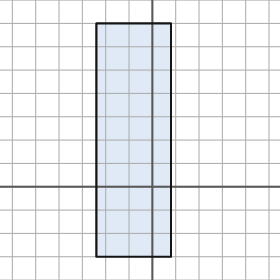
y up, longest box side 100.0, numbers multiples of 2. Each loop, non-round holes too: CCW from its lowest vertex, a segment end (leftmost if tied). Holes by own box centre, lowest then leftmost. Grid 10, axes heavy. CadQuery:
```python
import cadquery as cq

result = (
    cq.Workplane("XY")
    .moveTo(-24.0, -30.0)
    .lineTo(8.0, -30.0)
    .lineTo(8.0, 70.0)
    .lineTo(-24.0, 70.0)
    .close()
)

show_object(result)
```